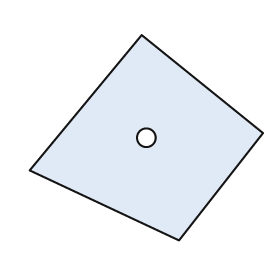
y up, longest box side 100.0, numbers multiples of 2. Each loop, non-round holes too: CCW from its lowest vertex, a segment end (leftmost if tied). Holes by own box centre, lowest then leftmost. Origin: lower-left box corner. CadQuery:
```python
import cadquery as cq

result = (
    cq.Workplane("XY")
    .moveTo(64.0, 0.0)
    .lineTo(100.0, 46.0)
    .lineTo(48.0, 88.0)
    .lineTo(0.0, 30.0)
    .close()
    .moveTo(50.0, 44.0)
    .circle(4.0)
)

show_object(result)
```